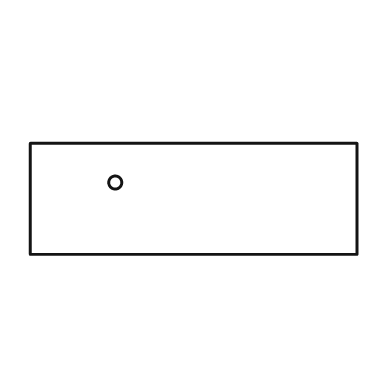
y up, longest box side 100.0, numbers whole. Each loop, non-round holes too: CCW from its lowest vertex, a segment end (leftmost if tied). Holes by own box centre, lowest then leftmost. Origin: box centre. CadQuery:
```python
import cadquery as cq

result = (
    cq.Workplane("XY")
    .moveTo(-50.0, -17.0)
    .lineTo(50.0, -17.0)
    .lineTo(50.0, 17.0)
    .lineTo(-50.0, 17.0)
    .close()
    .moveTo(-24.0, 5.0)
    .circle(2.0)
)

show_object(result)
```